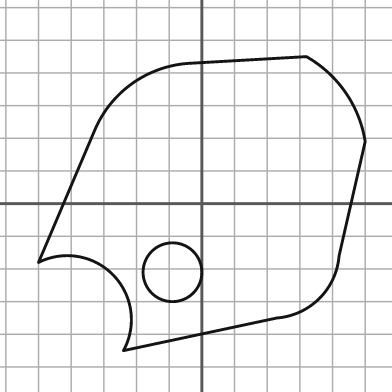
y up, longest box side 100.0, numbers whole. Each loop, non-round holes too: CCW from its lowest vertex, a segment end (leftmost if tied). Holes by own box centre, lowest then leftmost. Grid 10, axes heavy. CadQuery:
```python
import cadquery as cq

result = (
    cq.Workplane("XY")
    .moveTo(-24.0, -45.0)
    .lineTo(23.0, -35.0)
    .threePointArc((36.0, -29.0), (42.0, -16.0))
    .lineTo(50.0, 19.0)
    .threePointArc((44.0, 34.0), (32.0, 45.0))
    .lineTo(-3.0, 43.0)
    .threePointArc((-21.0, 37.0), (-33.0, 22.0))
    .lineTo(-50.0, -18.0)
    .threePointArc((-27.0, -22.0), (-24.0, -45.0))
    .close()
    .moveTo(-9.0, -21.0)
    .circle(9.0)
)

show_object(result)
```